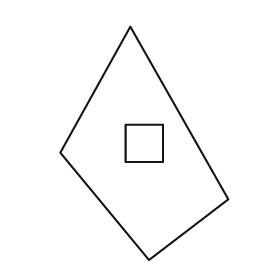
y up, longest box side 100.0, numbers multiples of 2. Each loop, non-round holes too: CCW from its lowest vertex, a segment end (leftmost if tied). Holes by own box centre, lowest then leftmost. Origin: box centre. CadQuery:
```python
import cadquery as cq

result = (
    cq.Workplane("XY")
    .moveTo(2.0, -50.0)
    .lineTo(36.0, -24.0)
    .lineTo(-6.0, 50.0)
    .lineTo(-36.0, -4.0)
    .close()
    .moveTo(-8.0, -8.0)
    .lineTo(8.0, -8.0)
    .lineTo(8.0, 8.0)
    .lineTo(-8.0, 8.0)
    .close()
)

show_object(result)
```